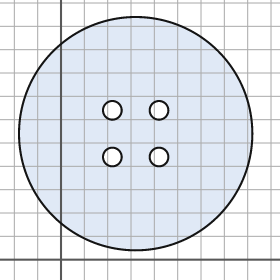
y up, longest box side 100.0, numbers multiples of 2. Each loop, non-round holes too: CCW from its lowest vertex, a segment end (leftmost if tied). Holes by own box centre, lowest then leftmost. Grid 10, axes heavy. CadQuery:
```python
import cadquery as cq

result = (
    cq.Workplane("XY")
    .moveTo(32.0, 54.0)
    .circle(50.0)
    .moveTo(22.0, 44.0)
    .circle(4.0)
    .moveTo(42.0, 44.0)
    .circle(4.0)
    .moveTo(22.0, 64.0)
    .circle(4.0)
    .moveTo(42.0, 64.0)
    .circle(4.0)
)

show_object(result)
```